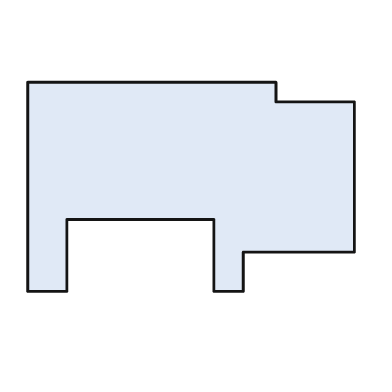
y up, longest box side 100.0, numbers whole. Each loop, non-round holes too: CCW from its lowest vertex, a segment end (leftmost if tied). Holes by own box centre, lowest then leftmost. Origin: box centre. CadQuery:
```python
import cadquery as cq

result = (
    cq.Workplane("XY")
    .moveTo(-50.0, -32.0)
    .lineTo(-38.0, -32.0)
    .lineTo(-38.0, -10.0)
    .lineTo(7.0, -10.0)
    .lineTo(7.0, -32.0)
    .lineTo(16.0, -32.0)
    .lineTo(16.0, -20.0)
    .lineTo(50.0, -20.0)
    .lineTo(50.0, 26.0)
    .lineTo(26.0, 26.0)
    .lineTo(26.0, 32.0)
    .lineTo(-50.0, 32.0)
    .close()
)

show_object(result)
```